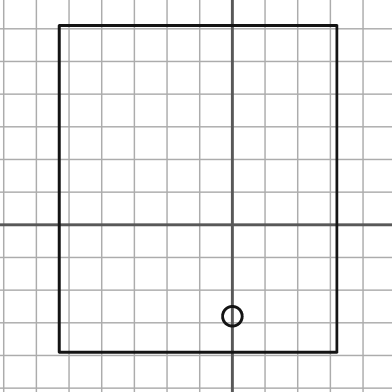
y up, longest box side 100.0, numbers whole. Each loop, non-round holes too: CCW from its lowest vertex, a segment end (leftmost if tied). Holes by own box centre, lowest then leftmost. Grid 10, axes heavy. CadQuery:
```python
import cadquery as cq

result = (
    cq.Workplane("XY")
    .moveTo(-53.0, -39.0)
    .lineTo(32.0, -39.0)
    .lineTo(32.0, 61.0)
    .lineTo(-53.0, 61.0)
    .close()
    .moveTo(0.0, -28.0)
    .circle(3.0)
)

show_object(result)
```